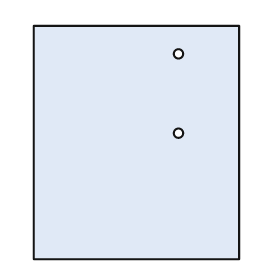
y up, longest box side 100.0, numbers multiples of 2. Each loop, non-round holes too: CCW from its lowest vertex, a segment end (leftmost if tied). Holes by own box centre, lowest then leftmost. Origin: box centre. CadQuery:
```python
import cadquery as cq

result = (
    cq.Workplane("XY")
    .moveTo(-44.0, -50.0)
    .lineTo(44.0, -50.0)
    .lineTo(44.0, 50.0)
    .lineTo(-44.0, 50.0)
    .close()
    .moveTo(18.0, 4.0)
    .circle(2.0)
    .moveTo(18.0, 38.0)
    .circle(2.0)
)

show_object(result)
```